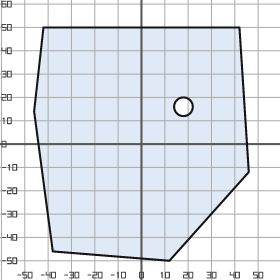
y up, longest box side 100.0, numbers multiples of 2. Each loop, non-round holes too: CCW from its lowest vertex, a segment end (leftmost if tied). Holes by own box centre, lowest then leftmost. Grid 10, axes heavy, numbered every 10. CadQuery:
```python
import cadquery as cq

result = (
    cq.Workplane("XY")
    .moveTo(12.0, -50.0)
    .lineTo(46.0, -12.0)
    .lineTo(42.0, 50.0)
    .lineTo(-42.0, 50.0)
    .lineTo(-46.0, 14.0)
    .lineTo(-38.0, -46.0)
    .close()
    .moveTo(18.0, 16.0)
    .circle(4.0)
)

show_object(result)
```